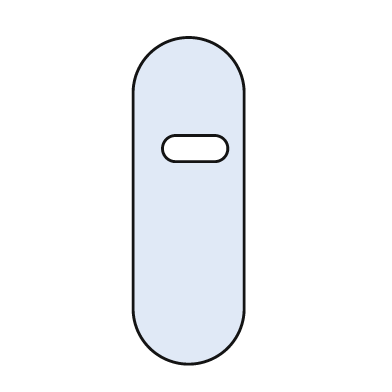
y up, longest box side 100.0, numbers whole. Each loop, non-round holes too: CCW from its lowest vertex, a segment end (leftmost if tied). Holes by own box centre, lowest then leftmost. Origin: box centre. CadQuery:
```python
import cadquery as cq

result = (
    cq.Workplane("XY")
    .moveTo(-17.0, -33.0)
    .threePointArc((0.0, -50.0), (17.0, -33.0))
    .lineTo(17.0, 33.0)
    .threePointArc((0.0, 50.0), (-17.0, 33.0))
    .close()
    .moveTo(-4.0, 12.0)
    .lineTo(8.0, 12.0)
    .threePointArc((12.0, 16.0), (8.0, 20.0))
    .lineTo(-4.0, 20.0)
    .threePointArc((-8.0, 16.0), (-4.0, 12.0))
    .close()
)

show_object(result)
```